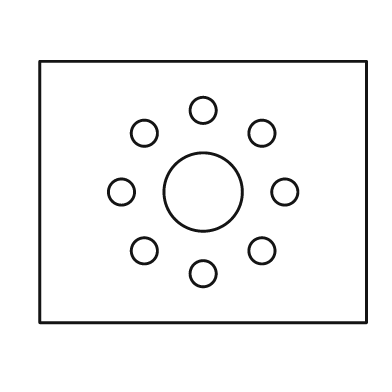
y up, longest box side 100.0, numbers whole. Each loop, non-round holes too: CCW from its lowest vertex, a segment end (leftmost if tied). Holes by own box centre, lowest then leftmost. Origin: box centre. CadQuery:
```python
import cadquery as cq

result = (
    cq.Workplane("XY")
    .moveTo(-50.0, -40.0)
    .lineTo(50.0, -40.0)
    .lineTo(50.0, 40.0)
    .lineTo(-50.0, 40.0)
    .close()
    .moveTo(0.0, -25.0)
    .circle(4.0)
    .moveTo(-18.0, -18.0)
    .circle(4.0)
    .moveTo(18.0, -18.0)
    .circle(4.0)
    .moveTo(-25.0, 0.0)
    .circle(4.0)
    .moveTo(0.0, 0.0)
    .circle(12.0)
    .moveTo(25.0, 0.0)
    .circle(4.0)
    .moveTo(-18.0, 18.0)
    .circle(4.0)
    .moveTo(18.0, 18.0)
    .circle(4.0)
    .moveTo(0.0, 25.0)
    .circle(4.0)
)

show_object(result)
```